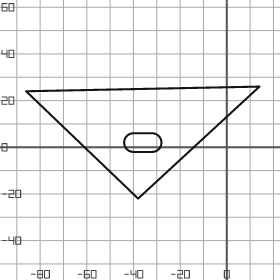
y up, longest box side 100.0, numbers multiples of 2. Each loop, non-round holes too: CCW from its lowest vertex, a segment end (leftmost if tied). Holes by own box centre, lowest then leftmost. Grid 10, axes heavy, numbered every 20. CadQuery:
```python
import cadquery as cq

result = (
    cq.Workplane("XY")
    .moveTo(-38.0, -22.0)
    .lineTo(14.0, 26.0)
    .lineTo(-86.0, 24.0)
    .close()
    .moveTo(-40.0, -2.0)
    .lineTo(-32.0, -2.0)
    .threePointArc((-28.0, 2.0), (-32.0, 6.0))
    .lineTo(-40.0, 6.0)
    .threePointArc((-44.0, 2.0), (-40.0, -2.0))
    .close()
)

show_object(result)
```